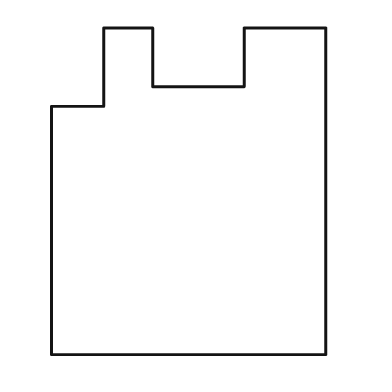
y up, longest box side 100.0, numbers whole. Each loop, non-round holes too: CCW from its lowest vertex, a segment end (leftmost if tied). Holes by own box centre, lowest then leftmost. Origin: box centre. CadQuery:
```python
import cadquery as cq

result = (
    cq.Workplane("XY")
    .moveTo(-42.0, -50.0)
    .lineTo(42.0, -50.0)
    .lineTo(42.0, 50.0)
    .lineTo(17.0, 50.0)
    .lineTo(17.0, 32.0)
    .lineTo(-11.0, 32.0)
    .lineTo(-11.0, 50.0)
    .lineTo(-26.0, 50.0)
    .lineTo(-26.0, 26.0)
    .lineTo(-42.0, 26.0)
    .close()
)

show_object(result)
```